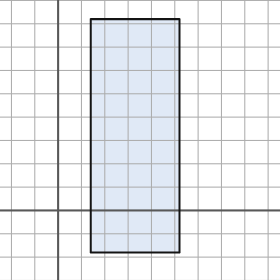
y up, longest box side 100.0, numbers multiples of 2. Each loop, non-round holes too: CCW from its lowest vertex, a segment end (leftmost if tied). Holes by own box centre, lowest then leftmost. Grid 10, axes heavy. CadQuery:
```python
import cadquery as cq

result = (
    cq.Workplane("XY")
    .moveTo(14.0, -18.0)
    .lineTo(52.0, -18.0)
    .lineTo(52.0, 82.0)
    .lineTo(14.0, 82.0)
    .close()
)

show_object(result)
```